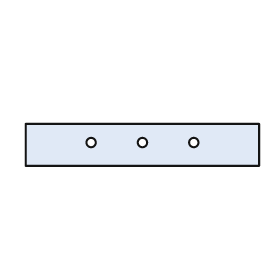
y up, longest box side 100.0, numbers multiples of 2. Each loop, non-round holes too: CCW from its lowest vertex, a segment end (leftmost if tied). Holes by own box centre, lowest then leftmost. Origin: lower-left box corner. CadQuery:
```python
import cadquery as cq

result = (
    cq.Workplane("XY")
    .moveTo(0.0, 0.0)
    .lineTo(100.0, 0.0)
    .lineTo(100.0, 18.0)
    .lineTo(0.0, 18.0)
    .close()
    .moveTo(28.0, 10.0)
    .circle(2.0)
    .moveTo(50.0, 10.0)
    .circle(2.0)
    .moveTo(72.0, 10.0)
    .circle(2.0)
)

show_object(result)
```